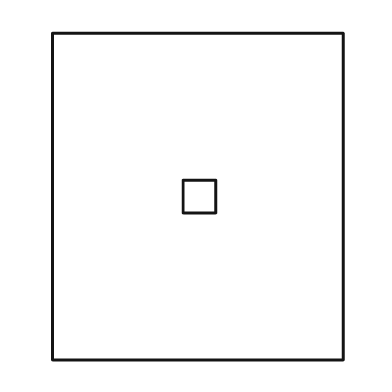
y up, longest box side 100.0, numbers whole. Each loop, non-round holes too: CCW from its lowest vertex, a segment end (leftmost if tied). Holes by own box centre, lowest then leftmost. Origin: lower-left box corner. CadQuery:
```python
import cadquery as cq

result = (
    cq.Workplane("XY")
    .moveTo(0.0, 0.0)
    .lineTo(89.0, 0.0)
    .lineTo(89.0, 100.0)
    .lineTo(0.0, 100.0)
    .close()
    .moveTo(40.0, 45.0)
    .lineTo(50.0, 45.0)
    .lineTo(50.0, 55.0)
    .lineTo(40.0, 55.0)
    .close()
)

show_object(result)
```